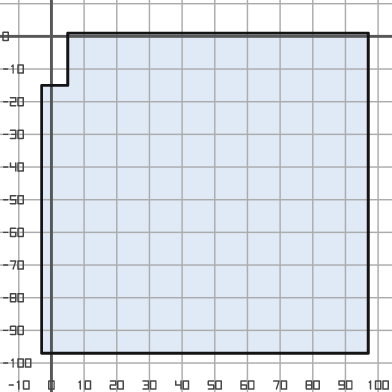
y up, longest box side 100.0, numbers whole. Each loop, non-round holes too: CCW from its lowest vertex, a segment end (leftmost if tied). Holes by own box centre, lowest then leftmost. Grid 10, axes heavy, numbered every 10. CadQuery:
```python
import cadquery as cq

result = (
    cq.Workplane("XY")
    .moveTo(-3.0, -97.0)
    .lineTo(97.0, -97.0)
    .lineTo(97.0, 1.0)
    .lineTo(5.0, 1.0)
    .lineTo(5.0, -15.0)
    .lineTo(-3.0, -15.0)
    .close()
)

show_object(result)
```